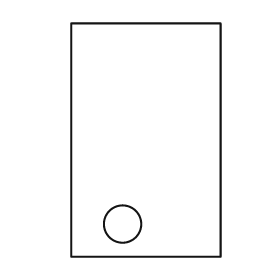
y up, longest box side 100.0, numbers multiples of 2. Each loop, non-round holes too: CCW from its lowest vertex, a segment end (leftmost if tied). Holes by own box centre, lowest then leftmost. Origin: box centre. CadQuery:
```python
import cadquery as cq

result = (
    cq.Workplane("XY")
    .moveTo(-32.0, -50.0)
    .lineTo(32.0, -50.0)
    .lineTo(32.0, 50.0)
    .lineTo(-32.0, 50.0)
    .close()
    .moveTo(-10.0, -36.0)
    .circle(8.0)
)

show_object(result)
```